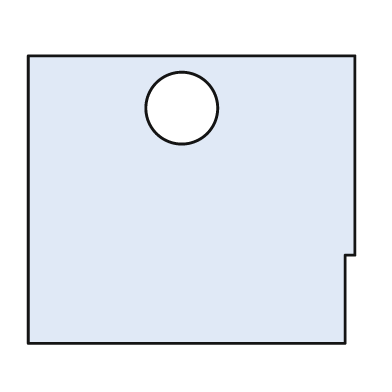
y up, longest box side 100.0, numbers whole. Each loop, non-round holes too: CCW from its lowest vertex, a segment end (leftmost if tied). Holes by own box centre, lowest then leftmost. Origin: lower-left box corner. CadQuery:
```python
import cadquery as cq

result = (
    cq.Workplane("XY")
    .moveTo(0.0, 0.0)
    .lineTo(97.0, 0.0)
    .lineTo(97.0, 27.0)
    .lineTo(100.0, 27.0)
    .lineTo(100.0, 88.0)
    .lineTo(0.0, 88.0)
    .close()
    .moveTo(47.0, 72.0)
    .circle(11.0)
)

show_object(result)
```